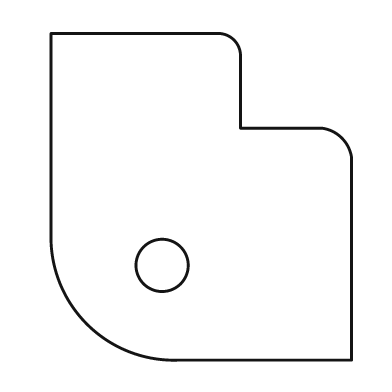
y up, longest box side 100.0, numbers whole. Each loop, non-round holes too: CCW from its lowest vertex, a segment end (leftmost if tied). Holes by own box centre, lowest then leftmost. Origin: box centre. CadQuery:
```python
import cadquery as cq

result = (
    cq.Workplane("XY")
    .moveTo(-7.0, -50.0)
    .lineTo(46.0, -50.0)
    .lineTo(46.0, 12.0)
    .threePointArc((43.0, 18.0), (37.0, 21.0))
    .lineTo(12.0, 21.0)
    .lineTo(12.0, 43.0)
    .threePointArc((10.0, 48.0), (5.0, 50.0))
    .lineTo(-46.0, 50.0)
    .lineTo(-46.0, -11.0)
    .threePointArc((-35.0, -39.0), (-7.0, -50.0))
    .close()
    .moveTo(-12.0, -21.0)
    .circle(8.0)
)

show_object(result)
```